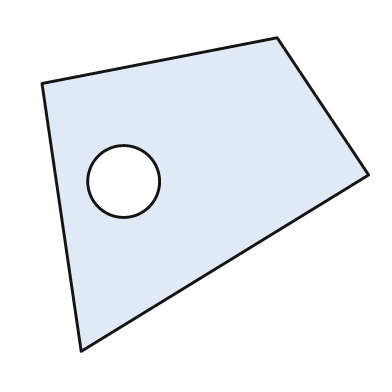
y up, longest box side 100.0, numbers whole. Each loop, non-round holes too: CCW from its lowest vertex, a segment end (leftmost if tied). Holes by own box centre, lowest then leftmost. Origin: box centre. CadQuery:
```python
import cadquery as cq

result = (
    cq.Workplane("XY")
    .moveTo(-38.0, -48.0)
    .lineTo(50.0, 6.0)
    .lineTo(22.0, 48.0)
    .lineTo(-50.0, 34.0)
    .close()
    .moveTo(-25.0, 4.0)
    .circle(11.0)
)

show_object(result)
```